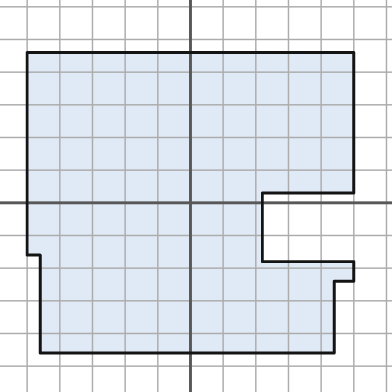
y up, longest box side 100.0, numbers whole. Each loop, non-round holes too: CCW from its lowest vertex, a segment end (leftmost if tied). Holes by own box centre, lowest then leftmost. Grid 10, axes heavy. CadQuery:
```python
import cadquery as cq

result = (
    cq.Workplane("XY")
    .moveTo(-46.0, -46.0)
    .lineTo(44.0, -46.0)
    .lineTo(44.0, -24.0)
    .lineTo(50.0, -24.0)
    .lineTo(50.0, -18.0)
    .lineTo(22.0, -18.0)
    .lineTo(22.0, 3.0)
    .lineTo(50.0, 3.0)
    .lineTo(50.0, 46.0)
    .lineTo(-50.0, 46.0)
    .lineTo(-50.0, -16.0)
    .lineTo(-46.0, -16.0)
    .close()
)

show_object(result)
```